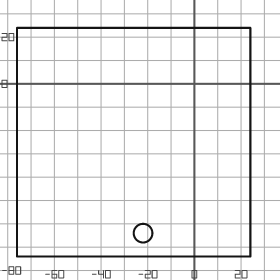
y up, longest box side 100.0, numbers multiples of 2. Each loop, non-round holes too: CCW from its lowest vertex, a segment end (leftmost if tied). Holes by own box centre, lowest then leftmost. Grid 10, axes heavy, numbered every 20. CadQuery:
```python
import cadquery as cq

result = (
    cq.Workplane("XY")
    .moveTo(-76.0, -74.0)
    .lineTo(24.0, -74.0)
    .lineTo(24.0, 24.0)
    .lineTo(-76.0, 24.0)
    .close()
    .moveTo(-22.0, -64.0)
    .circle(4.0)
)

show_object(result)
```